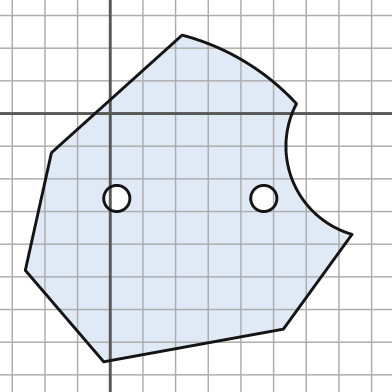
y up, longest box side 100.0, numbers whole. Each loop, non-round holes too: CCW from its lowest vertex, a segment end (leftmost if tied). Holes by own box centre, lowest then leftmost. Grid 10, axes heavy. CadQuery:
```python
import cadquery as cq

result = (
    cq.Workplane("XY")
    .moveTo(-2.0, -76.0)
    .lineTo(53.0, -66.0)
    .lineTo(74.0, -37.0)
    .threePointArc((56.0, -21.0), (57.0, 3.0))
    .threePointArc((41.0, 16.0), (22.0, 24.0))
    .lineTo(-18.0, -12.0)
    .lineTo(-26.0, -48.0)
    .close()
    .moveTo(2.0, -26.0)
    .circle(4.0)
    .moveTo(47.0, -26.0)
    .circle(4.0)
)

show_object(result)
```